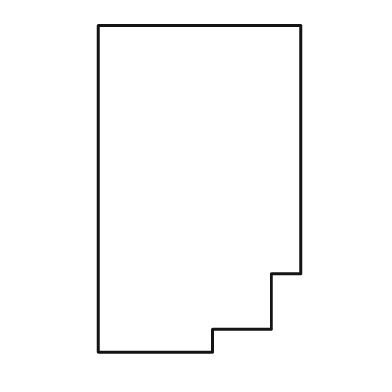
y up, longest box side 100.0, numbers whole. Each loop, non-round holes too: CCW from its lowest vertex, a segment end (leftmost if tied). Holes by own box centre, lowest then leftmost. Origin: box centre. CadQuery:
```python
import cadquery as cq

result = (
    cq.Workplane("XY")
    .moveTo(-31.0, -50.0)
    .lineTo(4.0, -50.0)
    .lineTo(4.0, -43.0)
    .lineTo(22.0, -43.0)
    .lineTo(22.0, -26.0)
    .lineTo(31.0, -26.0)
    .lineTo(31.0, 50.0)
    .lineTo(-31.0, 50.0)
    .close()
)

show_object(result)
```